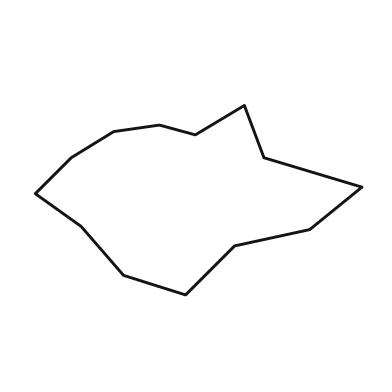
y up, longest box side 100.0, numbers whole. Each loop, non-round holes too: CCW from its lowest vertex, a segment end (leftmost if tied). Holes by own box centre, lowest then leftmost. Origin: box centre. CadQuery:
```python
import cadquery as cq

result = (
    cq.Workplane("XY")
    .moveTo(-4.0, -29.0)
    .lineTo(11.0, -14.0)
    .lineTo(34.0, -9.0)
    .lineTo(50.0, 4.0)
    .lineTo(20.0, 13.0)
    .lineTo(14.0, 29.0)
    .lineTo(-1.0, 20.0)
    .lineTo(-12.0, 23.0)
    .lineTo(-26.0, 21.0)
    .lineTo(-39.0, 13.0)
    .lineTo(-50.0, 2.0)
    .lineTo(-36.0, -8.0)
    .lineTo(-23.0, -23.0)
    .close()
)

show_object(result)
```